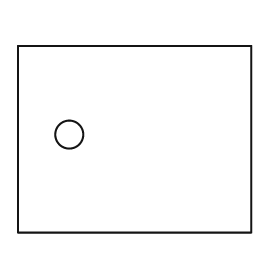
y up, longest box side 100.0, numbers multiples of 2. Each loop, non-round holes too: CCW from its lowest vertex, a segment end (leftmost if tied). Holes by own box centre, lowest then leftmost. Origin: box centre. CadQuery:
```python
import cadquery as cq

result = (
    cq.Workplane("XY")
    .moveTo(-50.0, -40.0)
    .lineTo(50.0, -40.0)
    .lineTo(50.0, 40.0)
    .lineTo(-50.0, 40.0)
    .close()
    .moveTo(-28.0, 2.0)
    .circle(6.0)
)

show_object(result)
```